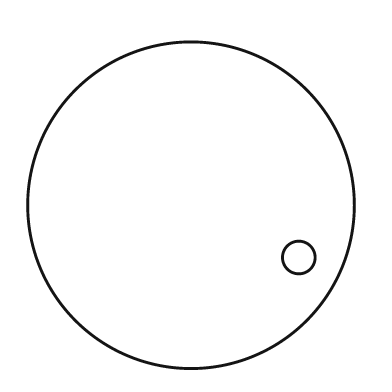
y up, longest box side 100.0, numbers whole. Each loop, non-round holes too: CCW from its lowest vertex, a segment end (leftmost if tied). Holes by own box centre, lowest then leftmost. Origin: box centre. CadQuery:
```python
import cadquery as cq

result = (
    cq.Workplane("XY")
    .moveTo(0.0, 0.0)
    .circle(50.0)
    .moveTo(33.0, -16.0)
    .circle(5.0)
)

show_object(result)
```